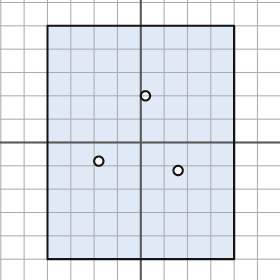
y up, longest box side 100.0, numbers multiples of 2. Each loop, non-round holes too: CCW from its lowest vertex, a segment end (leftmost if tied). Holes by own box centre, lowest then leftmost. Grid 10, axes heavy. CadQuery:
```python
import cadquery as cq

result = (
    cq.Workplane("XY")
    .moveTo(-40.0, -50.0)
    .lineTo(40.0, -50.0)
    .lineTo(40.0, 50.0)
    .lineTo(-40.0, 50.0)
    .close()
    .moveTo(16.0, -12.0)
    .circle(2.0)
    .moveTo(-18.0, -8.0)
    .circle(2.0)
    .moveTo(2.0, 20.0)
    .circle(2.0)
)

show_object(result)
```